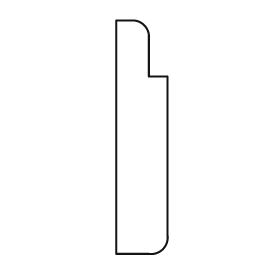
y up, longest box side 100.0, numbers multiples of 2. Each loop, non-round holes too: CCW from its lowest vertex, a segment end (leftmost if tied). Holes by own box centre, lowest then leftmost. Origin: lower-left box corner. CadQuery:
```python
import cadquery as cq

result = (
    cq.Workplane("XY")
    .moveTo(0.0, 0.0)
    .lineTo(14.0, 0.0)
    .threePointArc((20.0, 2.0), (22.0, 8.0))
    .lineTo(22.0, 76.0)
    .lineTo(14.0, 76.0)
    .lineTo(14.0, 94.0)
    .threePointArc((12.0, 98.0), (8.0, 100.0))
    .lineTo(0.0, 100.0)
    .close()
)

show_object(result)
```